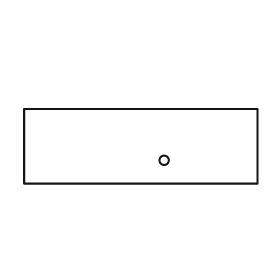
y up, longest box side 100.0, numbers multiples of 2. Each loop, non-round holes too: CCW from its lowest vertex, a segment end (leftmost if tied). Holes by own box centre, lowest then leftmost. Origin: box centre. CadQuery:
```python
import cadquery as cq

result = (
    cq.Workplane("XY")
    .moveTo(-50.0, -16.0)
    .lineTo(50.0, -16.0)
    .lineTo(50.0, 16.0)
    .lineTo(-50.0, 16.0)
    .close()
    .moveTo(10.0, -6.0)
    .circle(2.0)
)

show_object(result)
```